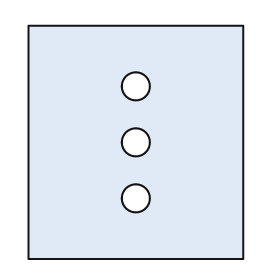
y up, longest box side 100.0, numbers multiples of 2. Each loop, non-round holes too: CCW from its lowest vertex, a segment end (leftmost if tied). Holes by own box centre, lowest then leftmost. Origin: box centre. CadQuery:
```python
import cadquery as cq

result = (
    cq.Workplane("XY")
    .moveTo(-46.0, -50.0)
    .lineTo(46.0, -50.0)
    .lineTo(46.0, 50.0)
    .lineTo(-46.0, 50.0)
    .close()
    .moveTo(0.0, -24.0)
    .circle(6.0)
    .moveTo(0.0, 0.0)
    .circle(6.0)
    .moveTo(0.0, 24.0)
    .circle(6.0)
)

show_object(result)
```